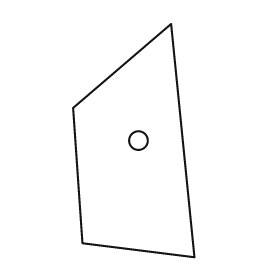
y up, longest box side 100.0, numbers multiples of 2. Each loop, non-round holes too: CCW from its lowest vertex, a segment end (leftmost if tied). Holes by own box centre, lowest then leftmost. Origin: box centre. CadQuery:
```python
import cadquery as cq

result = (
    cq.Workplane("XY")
    .moveTo(26.0, -50.0)
    .lineTo(16.0, 50.0)
    .lineTo(-26.0, 14.0)
    .lineTo(-22.0, -44.0)
    .close()
    .moveTo(2.0, 0.0)
    .circle(4.0)
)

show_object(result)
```